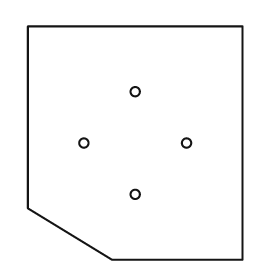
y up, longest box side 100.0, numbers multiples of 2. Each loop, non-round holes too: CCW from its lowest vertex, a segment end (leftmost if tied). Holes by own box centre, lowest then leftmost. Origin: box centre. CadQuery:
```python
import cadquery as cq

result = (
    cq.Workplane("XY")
    .moveTo(-10.0, -50.0)
    .lineTo(46.0, -50.0)
    .lineTo(46.0, 50.0)
    .lineTo(-46.0, 50.0)
    .lineTo(-46.0, -28.0)
    .close()
    .moveTo(0.0, -22.0)
    .circle(2.0)
    .moveTo(-22.0, 0.0)
    .circle(2.0)
    .moveTo(22.0, 0.0)
    .circle(2.0)
    .moveTo(0.0, 22.0)
    .circle(2.0)
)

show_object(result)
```